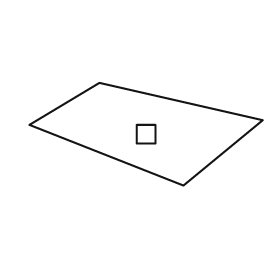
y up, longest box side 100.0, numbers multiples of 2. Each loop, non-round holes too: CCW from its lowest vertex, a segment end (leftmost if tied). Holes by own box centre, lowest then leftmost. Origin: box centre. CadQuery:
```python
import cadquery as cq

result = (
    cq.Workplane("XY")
    .moveTo(16.0, -22.0)
    .lineTo(50.0, 6.0)
    .lineTo(-20.0, 22.0)
    .lineTo(-50.0, 4.0)
    .close()
    .moveTo(-4.0, -4.0)
    .lineTo(4.0, -4.0)
    .lineTo(4.0, 4.0)
    .lineTo(-4.0, 4.0)
    .close()
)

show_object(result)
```